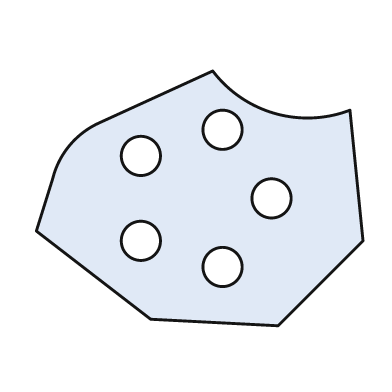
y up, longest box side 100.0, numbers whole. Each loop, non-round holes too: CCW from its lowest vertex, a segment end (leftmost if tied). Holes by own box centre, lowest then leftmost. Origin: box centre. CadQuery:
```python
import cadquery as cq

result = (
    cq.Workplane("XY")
    .moveTo(24.0, -39.0)
    .lineTo(50.0, -13.0)
    .lineTo(46.0, 27.0)
    .threePointArc((23.0, 26.0), (4.0, 39.0))
    .lineTo(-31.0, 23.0)
    .threePointArc((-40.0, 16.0), (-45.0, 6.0))
    .lineTo(-50.0, -10.0)
    .lineTo(-15.0, -37.0)
    .close()
    .moveTo(7.0, -21.0)
    .circle(6.0)
    .moveTo(-18.0, -13.0)
    .circle(6.0)
    .moveTo(22.0, 0.0)
    .circle(6.0)
    .moveTo(-18.0, 13.0)
    .circle(6.0)
    .moveTo(7.0, 21.0)
    .circle(6.0)
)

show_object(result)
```